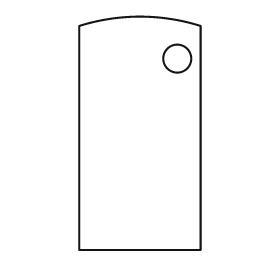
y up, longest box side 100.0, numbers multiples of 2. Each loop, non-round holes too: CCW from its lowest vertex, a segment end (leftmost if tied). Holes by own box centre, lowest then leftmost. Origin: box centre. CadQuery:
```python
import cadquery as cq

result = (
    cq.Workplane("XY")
    .moveTo(-26.0, -50.0)
    .lineTo(26.0, -50.0)
    .lineTo(26.0, 46.0)
    .threePointArc((0.0, 50.0), (-26.0, 46.0))
    .close()
    .moveTo(16.0, 32.0)
    .circle(6.0)
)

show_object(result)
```